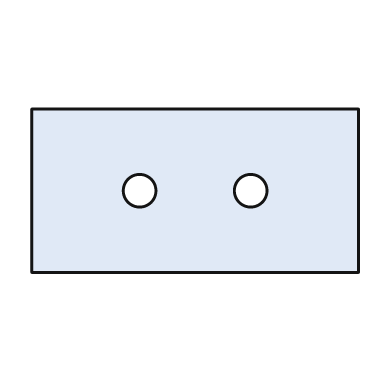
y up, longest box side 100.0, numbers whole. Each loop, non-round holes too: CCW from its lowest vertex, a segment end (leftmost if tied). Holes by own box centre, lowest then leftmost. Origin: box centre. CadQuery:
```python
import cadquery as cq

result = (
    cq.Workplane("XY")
    .moveTo(-50.0, -25.0)
    .lineTo(50.0, -25.0)
    .lineTo(50.0, 25.0)
    .lineTo(-50.0, 25.0)
    .close()
    .moveTo(-17.0, 0.0)
    .circle(5.0)
    .moveTo(17.0, 0.0)
    .circle(5.0)
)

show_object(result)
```